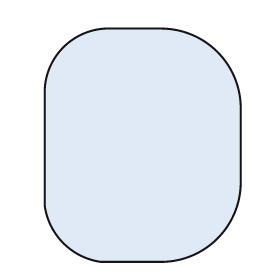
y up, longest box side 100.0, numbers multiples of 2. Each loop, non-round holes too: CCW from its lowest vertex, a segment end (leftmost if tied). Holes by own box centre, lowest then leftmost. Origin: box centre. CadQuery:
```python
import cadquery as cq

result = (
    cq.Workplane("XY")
    .moveTo(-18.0, -50.0)
    .lineTo(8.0, -50.0)
    .threePointArc((32.0, -40.0), (42.0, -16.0))
    .lineTo(42.0, 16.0)
    .threePointArc((32.0, 40.0), (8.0, 50.0))
    .lineTo(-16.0, 50.0)
    .threePointArc((-34.0, 42.0), (-42.0, 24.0))
    .lineTo(-42.0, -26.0)
    .threePointArc((-34.0, -42.0), (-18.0, -50.0))
    .close()
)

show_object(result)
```